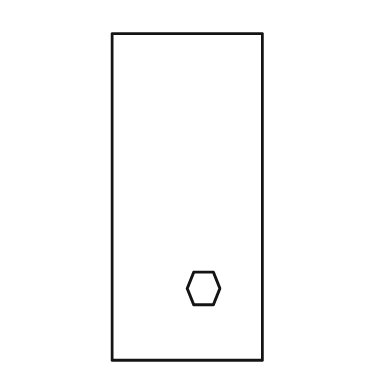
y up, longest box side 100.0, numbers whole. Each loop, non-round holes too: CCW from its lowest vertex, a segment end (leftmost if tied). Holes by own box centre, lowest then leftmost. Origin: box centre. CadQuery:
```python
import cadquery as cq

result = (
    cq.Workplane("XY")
    .moveTo(-23.0, -50.0)
    .lineTo(23.0, -50.0)
    .lineTo(23.0, 50.0)
    .lineTo(-23.0, 50.0)
    .close()
    .moveTo(2.0, -33.0)
    .lineTo(8.0, -33.0)
    .lineTo(10.0, -28.0)
    .lineTo(8.0, -23.0)
    .lineTo(2.0, -23.0)
    .lineTo(0.0, -28.0)
    .close()
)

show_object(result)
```